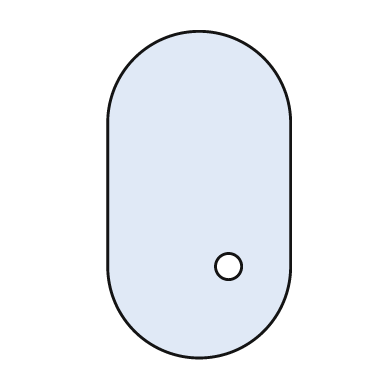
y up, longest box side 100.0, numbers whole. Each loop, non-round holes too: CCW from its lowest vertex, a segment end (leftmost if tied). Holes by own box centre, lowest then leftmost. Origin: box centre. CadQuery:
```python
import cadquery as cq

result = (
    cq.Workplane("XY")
    .moveTo(-28.0, -22.0)
    .threePointArc((0.0, -50.0), (28.0, -22.0))
    .lineTo(28.0, 22.0)
    .threePointArc((0.0, 50.0), (-28.0, 22.0))
    .close()
    .moveTo(9.0, -22.0)
    .circle(4.0)
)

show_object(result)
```